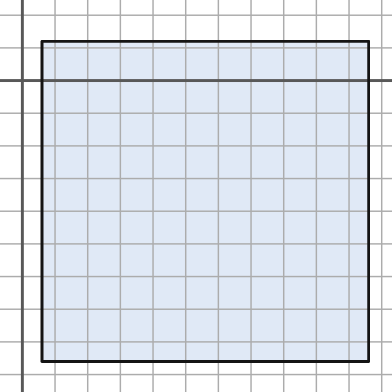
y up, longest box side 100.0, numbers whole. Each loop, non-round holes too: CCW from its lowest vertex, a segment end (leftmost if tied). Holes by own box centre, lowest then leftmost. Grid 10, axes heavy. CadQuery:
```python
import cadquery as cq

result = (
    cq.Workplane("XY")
    .moveTo(6.0, -86.0)
    .lineTo(106.0, -86.0)
    .lineTo(106.0, 12.0)
    .lineTo(6.0, 12.0)
    .close()
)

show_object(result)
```